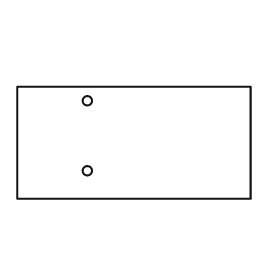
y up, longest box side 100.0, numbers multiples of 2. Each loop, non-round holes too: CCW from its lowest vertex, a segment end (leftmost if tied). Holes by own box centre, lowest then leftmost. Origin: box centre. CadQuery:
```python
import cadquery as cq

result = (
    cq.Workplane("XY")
    .moveTo(-50.0, -24.0)
    .lineTo(50.0, -24.0)
    .lineTo(50.0, 24.0)
    .lineTo(-50.0, 24.0)
    .close()
    .moveTo(-20.0, -12.0)
    .circle(2.0)
    .moveTo(-20.0, 18.0)
    .circle(2.0)
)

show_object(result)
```